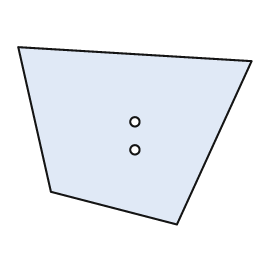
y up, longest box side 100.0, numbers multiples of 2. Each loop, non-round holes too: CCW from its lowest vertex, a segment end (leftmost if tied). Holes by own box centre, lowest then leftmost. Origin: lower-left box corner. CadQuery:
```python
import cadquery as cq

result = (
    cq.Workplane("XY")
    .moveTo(68.0, 0.0)
    .lineTo(100.0, 70.0)
    .lineTo(0.0, 76.0)
    .lineTo(14.0, 14.0)
    .close()
    .moveTo(50.0, 32.0)
    .circle(2.0)
    .moveTo(50.0, 44.0)
    .circle(2.0)
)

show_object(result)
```